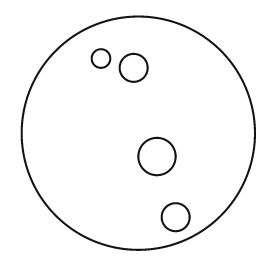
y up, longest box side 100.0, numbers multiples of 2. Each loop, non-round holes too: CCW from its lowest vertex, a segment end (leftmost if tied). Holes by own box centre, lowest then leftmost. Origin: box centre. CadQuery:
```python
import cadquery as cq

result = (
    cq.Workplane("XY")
    .moveTo(0.0, 0.0)
    .circle(50.0)
    .moveTo(16.0, -36.0)
    .circle(6.0)
    .moveTo(8.0, -10.0)
    .circle(8.0)
    .moveTo(-2.0, 28.0)
    .circle(6.0)
    .moveTo(-16.0, 32.0)
    .circle(4.0)
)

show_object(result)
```